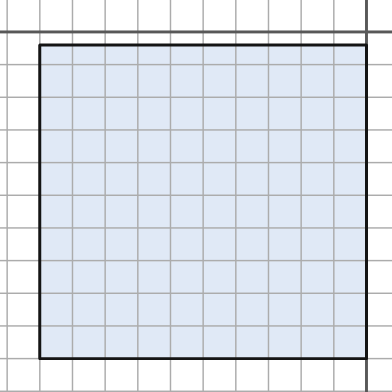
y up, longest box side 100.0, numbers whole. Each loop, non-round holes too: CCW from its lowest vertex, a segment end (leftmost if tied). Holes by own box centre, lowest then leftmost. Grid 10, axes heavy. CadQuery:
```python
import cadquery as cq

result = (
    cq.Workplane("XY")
    .moveTo(-100.0, -100.0)
    .lineTo(0.0, -100.0)
    .lineTo(0.0, -4.0)
    .lineTo(-100.0, -4.0)
    .close()
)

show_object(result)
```